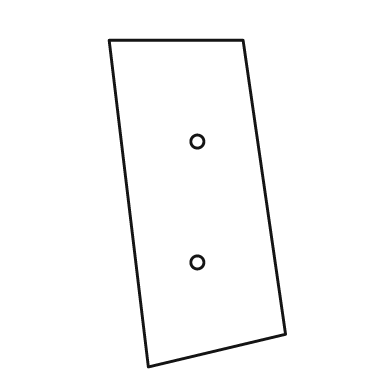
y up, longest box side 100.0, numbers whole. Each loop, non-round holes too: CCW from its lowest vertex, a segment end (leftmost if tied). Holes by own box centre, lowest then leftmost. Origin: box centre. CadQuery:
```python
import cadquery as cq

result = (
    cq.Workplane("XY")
    .moveTo(-15.0, -50.0)
    .lineTo(27.0, -40.0)
    .lineTo(14.0, 50.0)
    .lineTo(-27.0, 50.0)
    .close()
    .moveTo(0.0, -18.0)
    .circle(2.0)
    .moveTo(0.0, 19.0)
    .circle(2.0)
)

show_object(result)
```